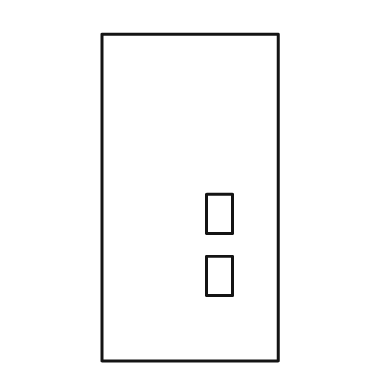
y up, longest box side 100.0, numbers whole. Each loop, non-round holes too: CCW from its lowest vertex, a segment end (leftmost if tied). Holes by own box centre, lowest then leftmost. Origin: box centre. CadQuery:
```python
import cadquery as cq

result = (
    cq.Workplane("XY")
    .moveTo(-27.0, -50.0)
    .lineTo(27.0, -50.0)
    .lineTo(27.0, 50.0)
    .lineTo(-27.0, 50.0)
    .close()
    .moveTo(5.0, -30.0)
    .lineTo(13.0, -30.0)
    .lineTo(13.0, -18.0)
    .lineTo(5.0, -18.0)
    .close()
    .moveTo(5.0, -11.0)
    .lineTo(13.0, -11.0)
    .lineTo(13.0, 1.0)
    .lineTo(5.0, 1.0)
    .close()
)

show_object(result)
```